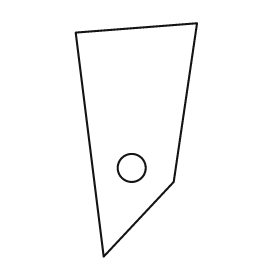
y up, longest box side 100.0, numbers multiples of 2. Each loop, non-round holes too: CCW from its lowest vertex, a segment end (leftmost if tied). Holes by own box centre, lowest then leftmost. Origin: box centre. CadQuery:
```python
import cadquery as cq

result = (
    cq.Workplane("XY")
    .moveTo(-14.0, -50.0)
    .lineTo(16.0, -18.0)
    .lineTo(26.0, 50.0)
    .lineTo(-26.0, 46.0)
    .close()
    .moveTo(-2.0, -12.0)
    .circle(6.0)
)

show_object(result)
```